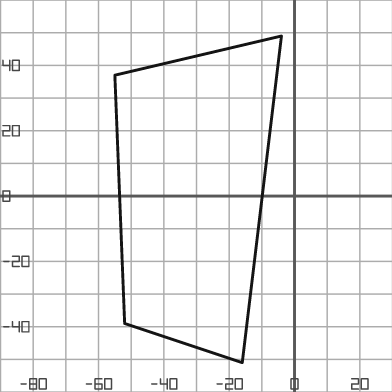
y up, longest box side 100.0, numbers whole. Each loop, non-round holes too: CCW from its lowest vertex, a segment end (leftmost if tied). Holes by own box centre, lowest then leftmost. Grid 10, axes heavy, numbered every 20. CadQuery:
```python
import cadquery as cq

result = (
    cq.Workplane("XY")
    .moveTo(-16.0, -51.0)
    .lineTo(-4.0, 49.0)
    .lineTo(-55.0, 37.0)
    .lineTo(-52.0, -39.0)
    .close()
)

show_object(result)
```